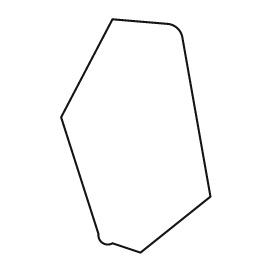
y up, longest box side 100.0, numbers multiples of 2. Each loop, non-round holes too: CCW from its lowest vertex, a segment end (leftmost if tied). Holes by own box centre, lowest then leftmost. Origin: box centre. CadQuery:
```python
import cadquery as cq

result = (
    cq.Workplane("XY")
    .moveTo(2.0, -50.0)
    .lineTo(32.0, -26.0)
    .lineTo(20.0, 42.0)
    .threePointArc((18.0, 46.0), (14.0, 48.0))
    .lineTo(-10.0, 50.0)
    .lineTo(-32.0, 8.0)
    .lineTo(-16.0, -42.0)
    .threePointArc((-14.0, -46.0), (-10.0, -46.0))
    .close()
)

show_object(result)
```